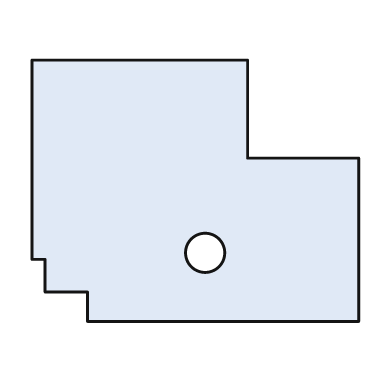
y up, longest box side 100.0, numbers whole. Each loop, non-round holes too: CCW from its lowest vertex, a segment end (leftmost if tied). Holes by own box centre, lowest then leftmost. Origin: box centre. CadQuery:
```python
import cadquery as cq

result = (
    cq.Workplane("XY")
    .moveTo(-33.0, -40.0)
    .lineTo(50.0, -40.0)
    .lineTo(50.0, 10.0)
    .lineTo(16.0, 10.0)
    .lineTo(16.0, 40.0)
    .lineTo(-50.0, 40.0)
    .lineTo(-50.0, -21.0)
    .lineTo(-46.0, -21.0)
    .lineTo(-46.0, -31.0)
    .lineTo(-33.0, -31.0)
    .close()
    .moveTo(3.0, -19.0)
    .circle(6.0)
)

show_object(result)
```